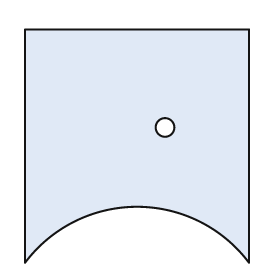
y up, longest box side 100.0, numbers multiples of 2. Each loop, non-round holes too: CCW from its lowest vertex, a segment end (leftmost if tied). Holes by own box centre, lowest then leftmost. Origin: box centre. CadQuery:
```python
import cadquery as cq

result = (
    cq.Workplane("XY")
    .moveTo(-48.0, -50.0)
    .threePointArc((0.0, -26.0), (48.0, -50.0))
    .lineTo(48.0, 50.0)
    .lineTo(-48.0, 50.0)
    .close()
    .moveTo(12.0, 8.0)
    .circle(4.0)
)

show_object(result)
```